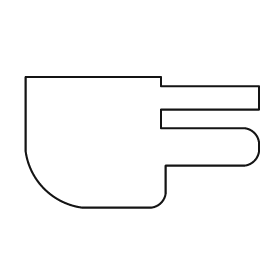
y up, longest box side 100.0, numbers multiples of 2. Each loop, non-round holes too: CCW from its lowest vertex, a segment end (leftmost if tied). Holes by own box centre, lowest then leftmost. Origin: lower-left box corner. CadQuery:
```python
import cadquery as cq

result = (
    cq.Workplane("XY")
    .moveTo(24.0, 0.0)
    .lineTo(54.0, 0.0)
    .threePointArc((58.0, 2.0), (60.0, 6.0))
    .lineTo(60.0, 18.0)
    .lineTo(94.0, 18.0)
    .threePointArc((98.0, 20.0), (100.0, 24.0))
    .lineTo(100.0, 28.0)
    .threePointArc((98.0, 32.0), (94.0, 34.0))
    .lineTo(58.0, 34.0)
    .lineTo(58.0, 42.0)
    .lineTo(100.0, 42.0)
    .lineTo(100.0, 52.0)
    .lineTo(58.0, 52.0)
    .lineTo(58.0, 56.0)
    .lineTo(0.0, 56.0)
    .lineTo(0.0, 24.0)
    .threePointArc((8.0, 8.0), (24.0, 0.0))
    .close()
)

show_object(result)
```